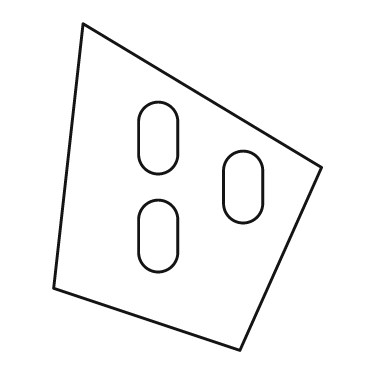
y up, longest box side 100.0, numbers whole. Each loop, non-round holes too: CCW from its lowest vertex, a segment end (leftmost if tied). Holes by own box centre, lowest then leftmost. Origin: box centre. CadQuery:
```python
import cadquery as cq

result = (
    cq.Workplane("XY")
    .moveTo(16.0, -50.0)
    .lineTo(41.0, 6.0)
    .lineTo(-32.0, 50.0)
    .lineTo(-41.0, -31.0)
    .close()
    .moveTo(-15.0, -20.0)
    .threePointArc((-9.0, -26.0), (-3.0, -20.0))
    .lineTo(-3.0, -10.0)
    .threePointArc((-9.0, -4.0), (-15.0, -10.0))
    .close()
    .moveTo(11.0, -5.0)
    .threePointArc((17.0, -11.0), (23.0, -5.0))
    .lineTo(23.0, 5.0)
    .threePointArc((17.0, 11.0), (11.0, 5.0))
    .close()
    .moveTo(-15.0, 10.0)
    .threePointArc((-9.0, 4.0), (-3.0, 10.0))
    .lineTo(-3.0, 20.0)
    .threePointArc((-9.0, 26.0), (-15.0, 20.0))
    .close()
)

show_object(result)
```